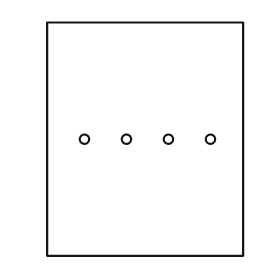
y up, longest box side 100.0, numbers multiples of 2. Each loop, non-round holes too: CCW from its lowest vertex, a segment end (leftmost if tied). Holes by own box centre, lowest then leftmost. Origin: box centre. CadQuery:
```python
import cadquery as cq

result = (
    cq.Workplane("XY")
    .moveTo(-42.0, -50.0)
    .lineTo(42.0, -50.0)
    .lineTo(42.0, 50.0)
    .lineTo(-42.0, 50.0)
    .close()
    .moveTo(-26.0, 0.0)
    .circle(2.0)
    .moveTo(-8.0, 0.0)
    .circle(2.0)
    .moveTo(10.0, 0.0)
    .circle(2.0)
    .moveTo(28.0, 0.0)
    .circle(2.0)
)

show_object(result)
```